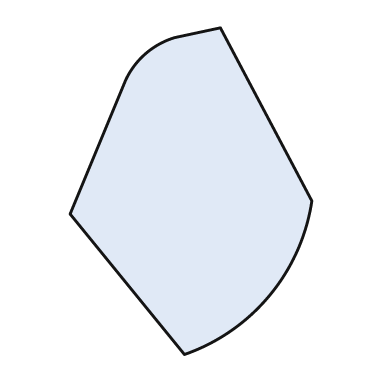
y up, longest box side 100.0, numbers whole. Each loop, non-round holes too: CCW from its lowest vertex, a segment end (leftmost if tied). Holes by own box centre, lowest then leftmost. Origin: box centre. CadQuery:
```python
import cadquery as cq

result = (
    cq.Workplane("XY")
    .moveTo(-2.0, -50.0)
    .threePointArc((24.0, -32.0), (37.0, -3.0))
    .lineTo(9.0, 50.0)
    .lineTo(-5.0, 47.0)
    .threePointArc((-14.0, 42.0), (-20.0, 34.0))
    .lineTo(-37.0, -7.0)
    .close()
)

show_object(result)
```